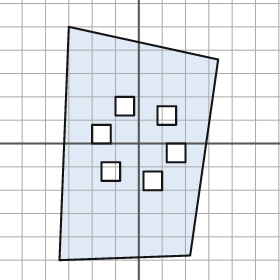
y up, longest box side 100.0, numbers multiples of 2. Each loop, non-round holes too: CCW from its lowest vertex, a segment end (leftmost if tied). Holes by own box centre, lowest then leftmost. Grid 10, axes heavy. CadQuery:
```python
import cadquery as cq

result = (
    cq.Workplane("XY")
    .moveTo(-34.0, -50.0)
    .lineTo(22.0, -48.0)
    .lineTo(34.0, 36.0)
    .lineTo(-30.0, 50.0)
    .close()
    .moveTo(2.0, -20.0)
    .lineTo(10.0, -20.0)
    .lineTo(10.0, -12.0)
    .lineTo(2.0, -12.0)
    .close()
    .moveTo(-16.0, -16.0)
    .lineTo(-8.0, -16.0)
    .lineTo(-8.0, -8.0)
    .lineTo(-16.0, -8.0)
    .close()
    .moveTo(12.0, -8.0)
    .lineTo(20.0, -8.0)
    .lineTo(20.0, 0.0)
    .lineTo(12.0, 0.0)
    .close()
    .moveTo(-20.0, 0.0)
    .lineTo(-12.0, 0.0)
    .lineTo(-12.0, 8.0)
    .lineTo(-20.0, 8.0)
    .close()
    .moveTo(8.0, 8.0)
    .lineTo(16.0, 8.0)
    .lineTo(16.0, 16.0)
    .lineTo(8.0, 16.0)
    .close()
    .moveTo(-10.0, 12.0)
    .lineTo(-2.0, 12.0)
    .lineTo(-2.0, 20.0)
    .lineTo(-10.0, 20.0)
    .close()
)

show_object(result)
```